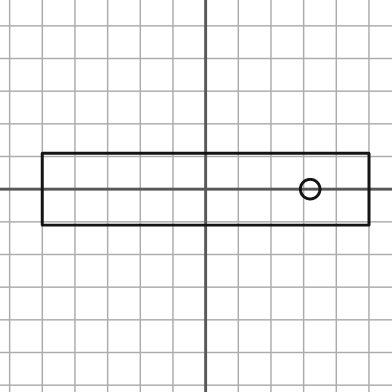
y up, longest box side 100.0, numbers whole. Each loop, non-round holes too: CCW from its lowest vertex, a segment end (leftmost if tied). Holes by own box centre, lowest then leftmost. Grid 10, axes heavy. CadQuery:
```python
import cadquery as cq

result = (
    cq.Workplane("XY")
    .moveTo(-50.0, -11.0)
    .lineTo(50.0, -11.0)
    .lineTo(50.0, 11.0)
    .lineTo(-50.0, 11.0)
    .close()
    .moveTo(32.0, 0.0)
    .circle(3.0)
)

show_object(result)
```